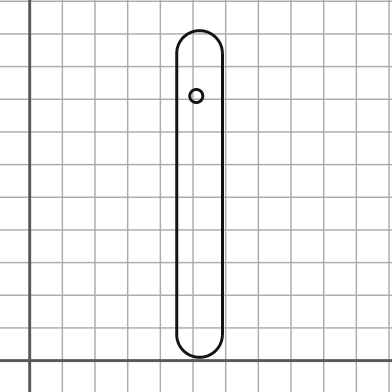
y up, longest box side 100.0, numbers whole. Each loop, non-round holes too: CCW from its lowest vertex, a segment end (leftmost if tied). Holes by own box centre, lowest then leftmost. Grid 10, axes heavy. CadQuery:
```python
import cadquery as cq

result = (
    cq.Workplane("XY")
    .moveTo(45.0, 8.0)
    .threePointArc((52.0, 1.0), (59.0, 8.0))
    .lineTo(59.0, 94.0)
    .threePointArc((52.0, 101.0), (45.0, 94.0))
    .close()
    .moveTo(51.0, 81.0)
    .circle(2.0)
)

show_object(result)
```